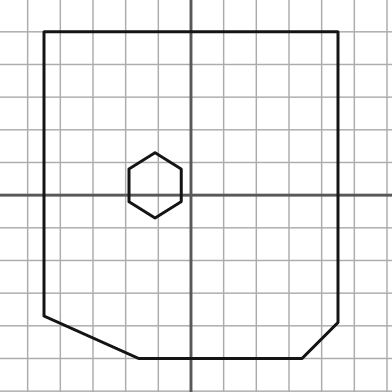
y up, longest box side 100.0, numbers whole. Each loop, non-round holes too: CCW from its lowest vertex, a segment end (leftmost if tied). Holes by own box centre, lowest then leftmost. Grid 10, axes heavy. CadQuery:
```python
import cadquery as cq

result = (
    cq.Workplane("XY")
    .moveTo(-16.0, -50.0)
    .lineTo(34.0, -50.0)
    .lineTo(45.0, -39.0)
    .lineTo(45.0, 50.0)
    .lineTo(-45.0, 50.0)
    .lineTo(-45.0, -37.0)
    .close()
    .moveTo(-11.0, -7.0)
    .lineTo(-3.0, -2.0)
    .lineTo(-3.0, 8.0)
    .lineTo(-11.0, 13.0)
    .lineTo(-19.0, 8.0)
    .lineTo(-19.0, -2.0)
    .close()
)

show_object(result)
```